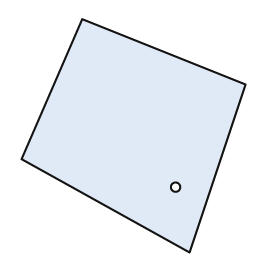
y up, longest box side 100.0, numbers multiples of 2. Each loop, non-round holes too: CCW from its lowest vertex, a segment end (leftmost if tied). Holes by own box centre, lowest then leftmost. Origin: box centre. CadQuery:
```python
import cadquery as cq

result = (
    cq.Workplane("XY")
    .moveTo(24.0, -50.0)
    .lineTo(48.0, 22.0)
    .lineTo(-22.0, 50.0)
    .lineTo(-48.0, -10.0)
    .close()
    .moveTo(18.0, -22.0)
    .circle(2.0)
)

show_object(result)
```